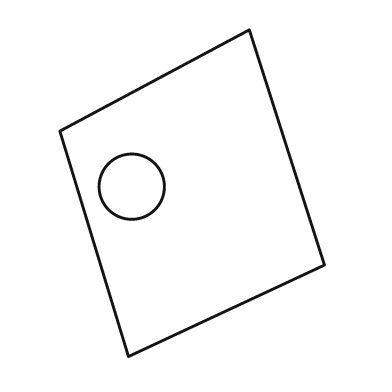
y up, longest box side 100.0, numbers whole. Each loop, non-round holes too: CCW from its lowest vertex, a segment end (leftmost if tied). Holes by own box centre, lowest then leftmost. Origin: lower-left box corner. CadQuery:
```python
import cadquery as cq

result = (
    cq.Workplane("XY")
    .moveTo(21.0, 0.0)
    .lineTo(81.0, 28.0)
    .lineTo(58.0, 100.0)
    .lineTo(0.0, 69.0)
    .close()
    .moveTo(22.0, 52.0)
    .circle(10.0)
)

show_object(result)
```